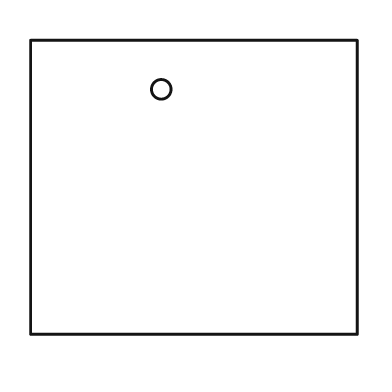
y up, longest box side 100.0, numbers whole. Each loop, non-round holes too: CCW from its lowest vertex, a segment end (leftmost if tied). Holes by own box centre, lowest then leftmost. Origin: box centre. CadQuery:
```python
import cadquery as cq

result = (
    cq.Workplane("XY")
    .moveTo(-50.0, -45.0)
    .lineTo(50.0, -45.0)
    .lineTo(50.0, 45.0)
    .lineTo(-50.0, 45.0)
    .close()
    .moveTo(-10.0, 30.0)
    .circle(3.0)
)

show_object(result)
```